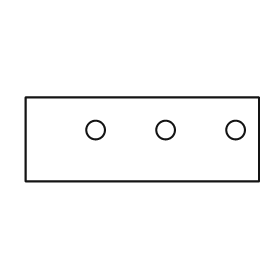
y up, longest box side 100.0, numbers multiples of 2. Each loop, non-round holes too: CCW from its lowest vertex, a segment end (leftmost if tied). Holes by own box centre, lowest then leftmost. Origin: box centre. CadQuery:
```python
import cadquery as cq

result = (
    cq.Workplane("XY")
    .moveTo(-50.0, -18.0)
    .lineTo(50.0, -18.0)
    .lineTo(50.0, 18.0)
    .lineTo(-50.0, 18.0)
    .close()
    .moveTo(-20.0, 4.0)
    .circle(4.0)
    .moveTo(10.0, 4.0)
    .circle(4.0)
    .moveTo(40.0, 4.0)
    .circle(4.0)
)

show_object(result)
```